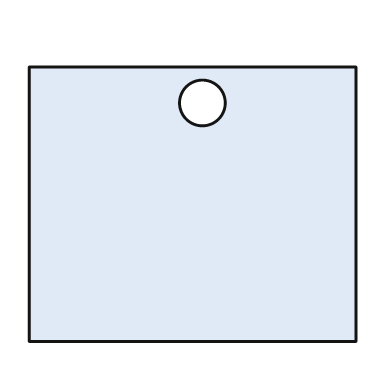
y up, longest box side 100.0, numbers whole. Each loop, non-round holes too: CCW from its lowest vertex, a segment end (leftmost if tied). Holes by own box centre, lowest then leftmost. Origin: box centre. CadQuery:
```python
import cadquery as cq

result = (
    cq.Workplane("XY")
    .moveTo(-50.0, -42.0)
    .lineTo(50.0, -42.0)
    .lineTo(50.0, 42.0)
    .lineTo(-50.0, 42.0)
    .close()
    .moveTo(3.0, 31.0)
    .circle(7.0)
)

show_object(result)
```